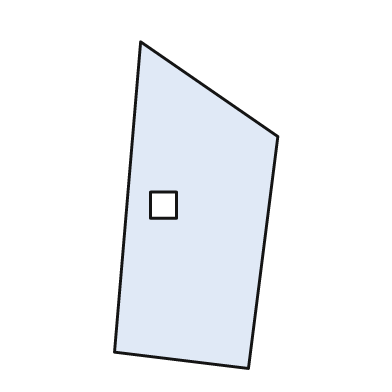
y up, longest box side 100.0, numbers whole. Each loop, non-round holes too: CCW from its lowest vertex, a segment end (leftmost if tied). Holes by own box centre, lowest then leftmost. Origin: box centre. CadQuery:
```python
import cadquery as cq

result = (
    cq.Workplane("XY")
    .moveTo(16.0, -50.0)
    .lineTo(25.0, 21.0)
    .lineTo(-17.0, 50.0)
    .lineTo(-25.0, -45.0)
    .close()
    .moveTo(-14.0, -4.0)
    .lineTo(-6.0, -4.0)
    .lineTo(-6.0, 4.0)
    .lineTo(-14.0, 4.0)
    .close()
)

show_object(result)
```